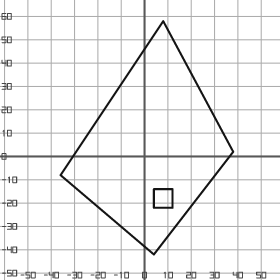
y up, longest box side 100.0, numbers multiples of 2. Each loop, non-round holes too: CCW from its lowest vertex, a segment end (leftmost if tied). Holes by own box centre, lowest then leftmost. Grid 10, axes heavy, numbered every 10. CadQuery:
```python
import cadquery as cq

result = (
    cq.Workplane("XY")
    .moveTo(4.0, -42.0)
    .lineTo(38.0, 2.0)
    .lineTo(8.0, 58.0)
    .lineTo(-36.0, -8.0)
    .close()
    .moveTo(4.0, -22.0)
    .lineTo(12.0, -22.0)
    .lineTo(12.0, -14.0)
    .lineTo(4.0, -14.0)
    .close()
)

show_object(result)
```